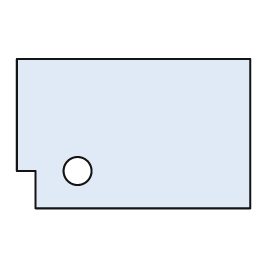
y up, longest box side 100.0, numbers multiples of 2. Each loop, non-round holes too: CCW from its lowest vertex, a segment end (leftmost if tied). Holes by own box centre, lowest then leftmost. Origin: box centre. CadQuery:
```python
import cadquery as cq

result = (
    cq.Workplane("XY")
    .moveTo(-42.0, -32.0)
    .lineTo(50.0, -32.0)
    .lineTo(50.0, 32.0)
    .lineTo(-50.0, 32.0)
    .lineTo(-50.0, -16.0)
    .lineTo(-42.0, -16.0)
    .close()
    .moveTo(-24.0, -16.0)
    .circle(6.0)
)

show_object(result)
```